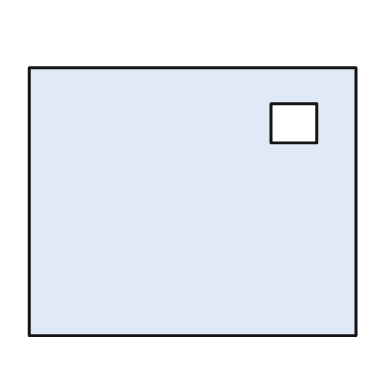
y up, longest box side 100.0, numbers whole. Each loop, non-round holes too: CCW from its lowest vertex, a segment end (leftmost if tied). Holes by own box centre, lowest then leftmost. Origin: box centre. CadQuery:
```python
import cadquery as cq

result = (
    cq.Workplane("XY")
    .moveTo(-50.0, -41.0)
    .lineTo(50.0, -41.0)
    .lineTo(50.0, 41.0)
    .lineTo(-50.0, 41.0)
    .close()
    .moveTo(24.0, 18.0)
    .lineTo(38.0, 18.0)
    .lineTo(38.0, 30.0)
    .lineTo(24.0, 30.0)
    .close()
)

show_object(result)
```